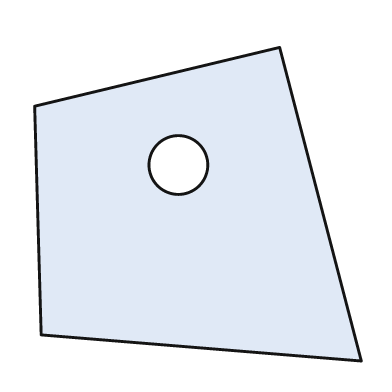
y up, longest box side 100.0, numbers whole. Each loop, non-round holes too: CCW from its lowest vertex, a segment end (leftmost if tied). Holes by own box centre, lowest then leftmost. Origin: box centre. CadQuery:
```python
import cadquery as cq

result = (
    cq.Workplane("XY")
    .moveTo(50.0, -48.0)
    .lineTo(25.0, 48.0)
    .lineTo(-50.0, 30.0)
    .lineTo(-48.0, -40.0)
    .close()
    .moveTo(-6.0, 12.0)
    .circle(9.0)
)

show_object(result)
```